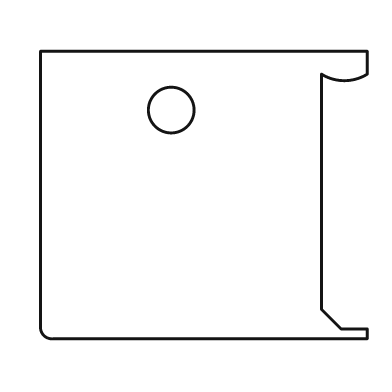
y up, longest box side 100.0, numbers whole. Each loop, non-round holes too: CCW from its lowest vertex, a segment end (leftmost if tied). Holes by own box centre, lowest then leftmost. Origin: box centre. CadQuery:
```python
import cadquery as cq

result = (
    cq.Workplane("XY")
    .moveTo(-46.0, -44.0)
    .lineTo(50.0, -44.0)
    .lineTo(50.0, -41.0)
    .lineTo(42.0, -41.0)
    .lineTo(36.0, -35.0)
    .lineTo(36.0, 37.0)
    .threePointArc((43.0, 35.0), (50.0, 37.0))
    .lineTo(50.0, 44.0)
    .lineTo(-50.0, 44.0)
    .lineTo(-50.0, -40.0)
    .threePointArc((-49.0, -43.0), (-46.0, -44.0))
    .close()
    .moveTo(-10.0, 26.0)
    .circle(7.0)
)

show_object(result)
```